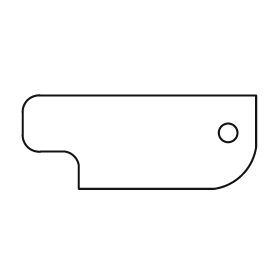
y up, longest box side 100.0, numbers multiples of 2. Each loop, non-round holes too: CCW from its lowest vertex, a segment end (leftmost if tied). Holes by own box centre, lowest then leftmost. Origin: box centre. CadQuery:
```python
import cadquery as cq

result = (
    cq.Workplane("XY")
    .moveTo(-26.0, -20.0)
    .lineTo(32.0, -20.0)
    .threePointArc((44.0, -14.0), (50.0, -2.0))
    .lineTo(50.0, 20.0)
    .lineTo(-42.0, 20.0)
    .threePointArc((-48.0, 18.0), (-50.0, 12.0))
    .lineTo(-50.0, 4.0)
    .threePointArc((-48.0, -2.0), (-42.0, -4.0))
    .lineTo(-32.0, -4.0)
    .threePointArc((-28.0, -6.0), (-26.0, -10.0))
    .close()
    .moveTo(38.0, 4.0)
    .circle(4.0)
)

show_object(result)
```